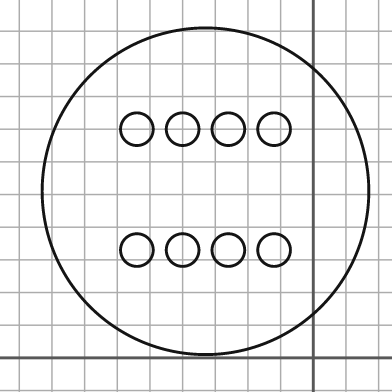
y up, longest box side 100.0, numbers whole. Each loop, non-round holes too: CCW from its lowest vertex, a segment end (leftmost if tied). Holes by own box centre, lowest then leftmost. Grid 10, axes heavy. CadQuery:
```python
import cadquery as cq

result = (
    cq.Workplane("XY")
    .moveTo(-33.0, 51.0)
    .circle(50.0)
    .moveTo(-54.0, 33.0)
    .circle(5.0)
    .moveTo(-40.0, 33.0)
    .circle(5.0)
    .moveTo(-26.0, 33.0)
    .circle(5.0)
    .moveTo(-12.0, 33.0)
    .circle(5.0)
    .moveTo(-54.0, 70.0)
    .circle(5.0)
    .moveTo(-40.0, 70.0)
    .circle(5.0)
    .moveTo(-26.0, 70.0)
    .circle(5.0)
    .moveTo(-12.0, 70.0)
    .circle(5.0)
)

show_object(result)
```